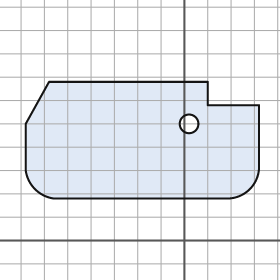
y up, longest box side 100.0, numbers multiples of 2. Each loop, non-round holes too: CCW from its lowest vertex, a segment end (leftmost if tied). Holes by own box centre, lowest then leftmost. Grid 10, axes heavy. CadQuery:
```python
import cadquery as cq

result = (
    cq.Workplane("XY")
    .moveTo(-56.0, 18.0)
    .lineTo(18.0, 18.0)
    .threePointArc((28.0, 22.0), (32.0, 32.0))
    .lineTo(32.0, 58.0)
    .lineTo(10.0, 58.0)
    .lineTo(10.0, 68.0)
    .lineTo(-58.0, 68.0)
    .lineTo(-68.0, 50.0)
    .lineTo(-68.0, 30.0)
    .threePointArc((-64.0, 22.0), (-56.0, 18.0))
    .close()
    .moveTo(2.0, 50.0)
    .circle(4.0)
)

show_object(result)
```